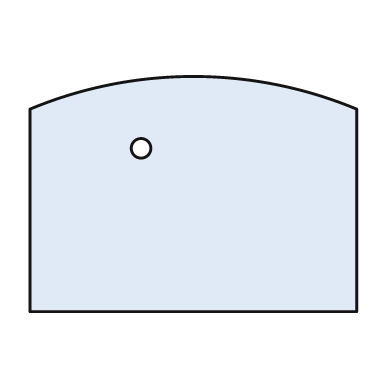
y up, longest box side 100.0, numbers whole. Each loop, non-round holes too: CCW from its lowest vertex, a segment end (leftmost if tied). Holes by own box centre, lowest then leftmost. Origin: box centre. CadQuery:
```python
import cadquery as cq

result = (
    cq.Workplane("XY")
    .moveTo(-50.0, -36.0)
    .lineTo(50.0, -36.0)
    .lineTo(50.0, 26.0)
    .threePointArc((0.0, 36.0), (-50.0, 26.0))
    .close()
    .moveTo(-16.0, 14.0)
    .circle(3.0)
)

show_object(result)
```